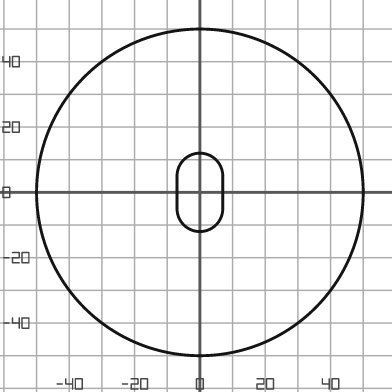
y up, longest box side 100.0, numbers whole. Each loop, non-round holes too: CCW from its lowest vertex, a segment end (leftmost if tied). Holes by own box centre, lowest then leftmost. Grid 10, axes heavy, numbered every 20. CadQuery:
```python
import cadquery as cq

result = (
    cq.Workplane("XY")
    .moveTo(0.0, 0.0)
    .circle(50.0)
    .moveTo(-7.0, -5.0)
    .threePointArc((0.0, -12.0), (7.0, -5.0))
    .lineTo(7.0, 5.0)
    .threePointArc((0.0, 12.0), (-7.0, 5.0))
    .close()
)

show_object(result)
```